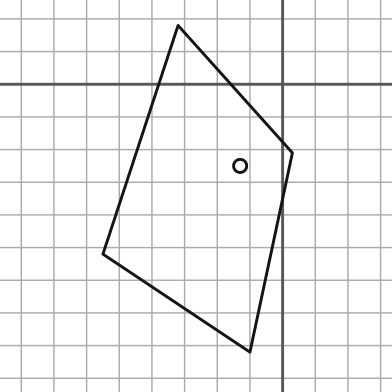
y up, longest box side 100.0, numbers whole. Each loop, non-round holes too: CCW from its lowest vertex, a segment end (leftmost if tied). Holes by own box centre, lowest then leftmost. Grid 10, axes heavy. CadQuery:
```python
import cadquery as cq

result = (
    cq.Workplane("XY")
    .moveTo(-10.0, -82.0)
    .lineTo(3.0, -21.0)
    .lineTo(-32.0, 18.0)
    .lineTo(-55.0, -52.0)
    .close()
    .moveTo(-13.0, -25.0)
    .circle(2.0)
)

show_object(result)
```